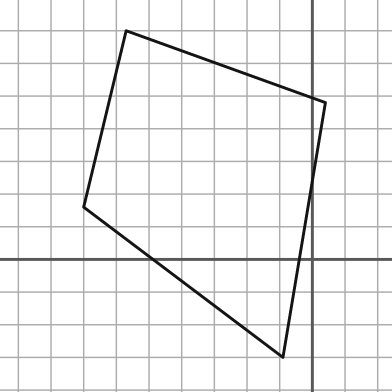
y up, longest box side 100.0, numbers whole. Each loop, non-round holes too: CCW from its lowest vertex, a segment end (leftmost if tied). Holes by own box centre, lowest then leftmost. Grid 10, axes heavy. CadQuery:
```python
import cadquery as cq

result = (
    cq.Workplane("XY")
    .moveTo(-9.0, -30.0)
    .lineTo(4.0, 48.0)
    .lineTo(-57.0, 70.0)
    .lineTo(-70.0, 16.0)
    .close()
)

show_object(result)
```